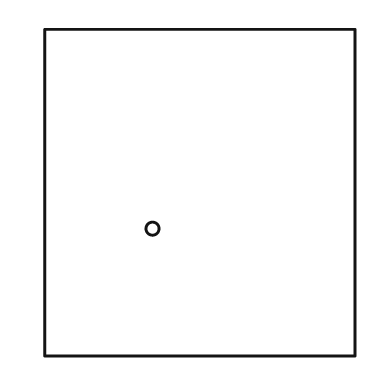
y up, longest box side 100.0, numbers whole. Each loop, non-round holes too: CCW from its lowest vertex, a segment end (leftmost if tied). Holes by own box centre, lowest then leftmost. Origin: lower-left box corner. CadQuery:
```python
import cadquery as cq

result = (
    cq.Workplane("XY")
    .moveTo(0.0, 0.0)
    .lineTo(95.0, 0.0)
    .lineTo(95.0, 100.0)
    .lineTo(0.0, 100.0)
    .close()
    .moveTo(33.0, 39.0)
    .circle(2.0)
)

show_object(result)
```